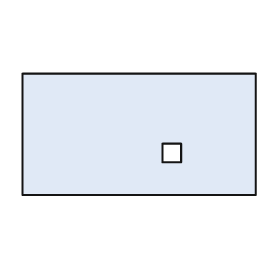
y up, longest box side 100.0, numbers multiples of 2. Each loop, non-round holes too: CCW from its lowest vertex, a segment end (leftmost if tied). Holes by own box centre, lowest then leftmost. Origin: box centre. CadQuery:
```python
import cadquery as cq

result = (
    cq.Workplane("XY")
    .moveTo(-50.0, -26.0)
    .lineTo(50.0, -26.0)
    .lineTo(50.0, 26.0)
    .lineTo(-50.0, 26.0)
    .close()
    .moveTo(10.0, -12.0)
    .lineTo(18.0, -12.0)
    .lineTo(18.0, -4.0)
    .lineTo(10.0, -4.0)
    .close()
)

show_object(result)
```